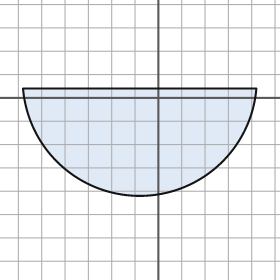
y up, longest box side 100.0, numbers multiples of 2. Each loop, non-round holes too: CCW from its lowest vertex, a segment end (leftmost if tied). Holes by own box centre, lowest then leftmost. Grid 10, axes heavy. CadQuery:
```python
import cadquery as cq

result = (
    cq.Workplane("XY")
    .moveTo(-58.0, 4.0)
    .threePointArc((-8.0, -42.0), (42.0, 4.0))
    .close()
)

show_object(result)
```